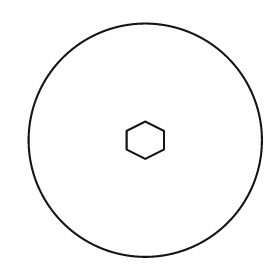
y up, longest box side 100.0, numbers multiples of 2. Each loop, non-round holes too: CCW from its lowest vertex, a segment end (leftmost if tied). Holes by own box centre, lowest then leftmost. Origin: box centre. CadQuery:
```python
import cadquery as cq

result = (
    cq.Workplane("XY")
    .moveTo(0.0, 0.0)
    .circle(50.0)
    .moveTo(0.0, -8.0)
    .lineTo(8.0, -4.0)
    .lineTo(8.0, 4.0)
    .lineTo(0.0, 8.0)
    .lineTo(-8.0, 4.0)
    .lineTo(-8.0, -4.0)
    .close()
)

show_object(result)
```